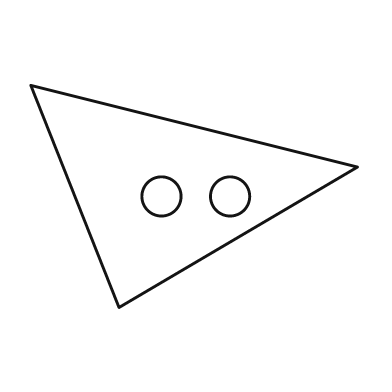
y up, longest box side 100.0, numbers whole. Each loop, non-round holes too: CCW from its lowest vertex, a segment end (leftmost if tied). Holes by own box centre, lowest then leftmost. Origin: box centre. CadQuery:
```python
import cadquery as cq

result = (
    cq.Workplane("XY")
    .moveTo(-23.0, -34.0)
    .lineTo(50.0, 9.0)
    .lineTo(-50.0, 34.0)
    .close()
    .moveTo(-10.0, 0.0)
    .circle(6.0)
    .moveTo(11.0, 0.0)
    .circle(6.0)
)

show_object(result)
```